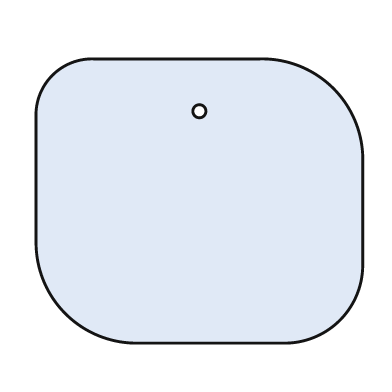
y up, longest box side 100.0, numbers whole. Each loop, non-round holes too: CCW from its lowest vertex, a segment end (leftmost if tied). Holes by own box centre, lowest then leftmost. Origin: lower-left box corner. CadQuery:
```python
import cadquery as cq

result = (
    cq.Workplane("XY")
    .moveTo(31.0, 0.0)
    .lineTo(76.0, 0.0)
    .threePointArc((93.0, 7.0), (100.0, 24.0))
    .lineTo(100.0, 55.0)
    .threePointArc((91.0, 78.0), (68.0, 87.0))
    .lineTo(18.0, 87.0)
    .threePointArc((5.0, 82.0), (0.0, 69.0))
    .lineTo(0.0, 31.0)
    .threePointArc((9.0, 9.0), (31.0, 0.0))
    .close()
    .moveTo(50.0, 71.0)
    .circle(2.0)
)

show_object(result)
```